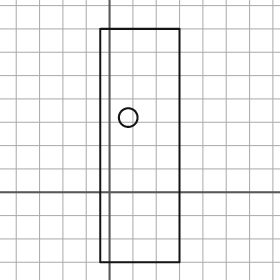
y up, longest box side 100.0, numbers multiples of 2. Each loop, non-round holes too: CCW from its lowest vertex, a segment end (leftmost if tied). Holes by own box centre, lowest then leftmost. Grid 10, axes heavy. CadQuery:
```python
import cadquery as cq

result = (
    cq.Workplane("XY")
    .moveTo(-4.0, -30.0)
    .lineTo(30.0, -30.0)
    .lineTo(30.0, 70.0)
    .lineTo(-4.0, 70.0)
    .close()
    .moveTo(8.0, 32.0)
    .circle(4.0)
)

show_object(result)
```